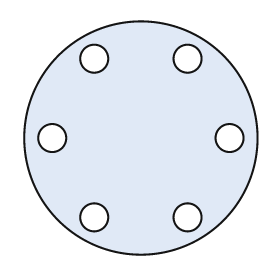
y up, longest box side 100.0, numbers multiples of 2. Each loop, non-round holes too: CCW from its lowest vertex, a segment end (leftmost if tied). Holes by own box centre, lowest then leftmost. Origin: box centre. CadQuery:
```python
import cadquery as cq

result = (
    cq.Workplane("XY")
    .moveTo(0.0, 0.0)
    .circle(50.0)
    .moveTo(-20.0, -34.0)
    .circle(6.0)
    .moveTo(20.0, -34.0)
    .circle(6.0)
    .moveTo(-38.0, 0.0)
    .circle(6.0)
    .moveTo(38.0, 0.0)
    .circle(6.0)
    .moveTo(-20.0, 34.0)
    .circle(6.0)
    .moveTo(20.0, 34.0)
    .circle(6.0)
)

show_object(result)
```